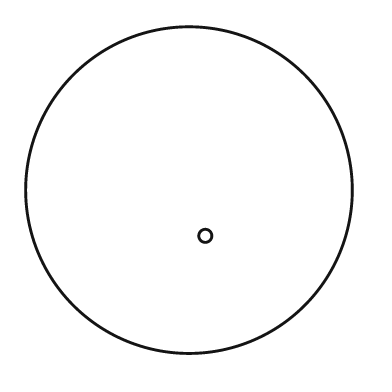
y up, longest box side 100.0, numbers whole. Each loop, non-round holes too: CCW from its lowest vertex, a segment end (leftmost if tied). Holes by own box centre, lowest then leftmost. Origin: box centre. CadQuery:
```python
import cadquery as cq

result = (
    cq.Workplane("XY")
    .moveTo(0.0, 0.0)
    .circle(50.0)
    .moveTo(5.0, -14.0)
    .circle(2.0)
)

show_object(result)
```